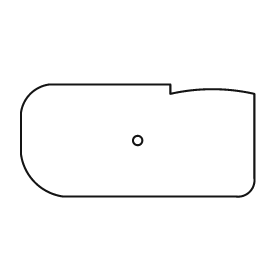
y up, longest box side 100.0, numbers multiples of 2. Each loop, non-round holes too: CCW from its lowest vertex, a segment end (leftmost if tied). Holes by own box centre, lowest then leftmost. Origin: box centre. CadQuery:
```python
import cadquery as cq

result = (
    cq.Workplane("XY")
    .moveTo(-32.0, -24.0)
    .lineTo(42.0, -24.0)
    .threePointArc((48.0, -22.0), (50.0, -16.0))
    .lineTo(50.0, 20.0)
    .threePointArc((32.0, 22.0), (14.0, 20.0))
    .lineTo(14.0, 24.0)
    .lineTo(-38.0, 24.0)
    .threePointArc((-46.0, 20.0), (-50.0, 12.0))
    .lineTo(-50.0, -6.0)
    .threePointArc((-44.0, -18.0), (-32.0, -24.0))
    .close()
    .moveTo(0.0, 0.0)
    .circle(2.0)
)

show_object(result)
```